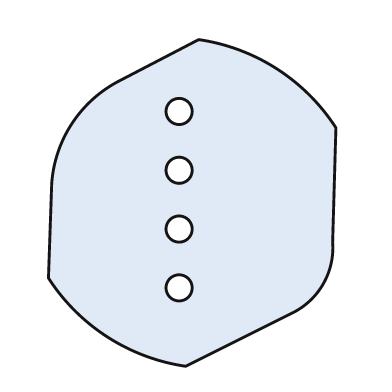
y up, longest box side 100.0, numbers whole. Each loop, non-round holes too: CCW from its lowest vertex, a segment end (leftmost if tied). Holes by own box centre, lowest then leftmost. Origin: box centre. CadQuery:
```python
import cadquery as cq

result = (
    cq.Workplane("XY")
    .moveTo(-2.0, -50.0)
    .lineTo(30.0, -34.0)
    .threePointArc((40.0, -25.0), (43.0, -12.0))
    .lineTo(44.0, 23.0)
    .threePointArc((26.0, 41.0), (2.0, 50.0))
    .lineTo(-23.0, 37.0)
    .threePointArc((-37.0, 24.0), (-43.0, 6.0))
    .lineTo(-44.0, -23.0)
    .threePointArc((-26.0, -41.0), (-2.0, -50.0))
    .close()
    .moveTo(-4.0, -26.0)
    .circle(4.0)
    .moveTo(-4.0, -8.0)
    .circle(4.0)
    .moveTo(-4.0, 10.0)
    .circle(4.0)
    .moveTo(-4.0, 28.0)
    .circle(4.0)
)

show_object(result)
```